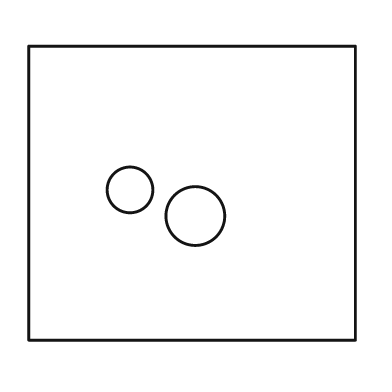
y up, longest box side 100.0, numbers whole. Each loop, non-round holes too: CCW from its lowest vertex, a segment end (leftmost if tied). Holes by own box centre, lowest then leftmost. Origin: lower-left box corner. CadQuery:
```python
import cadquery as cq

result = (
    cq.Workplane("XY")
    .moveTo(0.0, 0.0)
    .lineTo(100.0, 0.0)
    .lineTo(100.0, 90.0)
    .lineTo(0.0, 90.0)
    .close()
    .moveTo(51.0, 38.0)
    .circle(9.0)
    .moveTo(31.0, 46.0)
    .circle(7.0)
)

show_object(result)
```